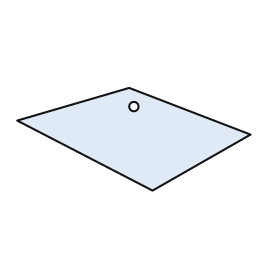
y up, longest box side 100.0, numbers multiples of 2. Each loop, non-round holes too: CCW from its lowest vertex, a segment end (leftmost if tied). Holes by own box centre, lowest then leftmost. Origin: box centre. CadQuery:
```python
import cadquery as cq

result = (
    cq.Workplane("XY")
    .moveTo(8.0, -22.0)
    .lineTo(50.0, 2.0)
    .lineTo(-2.0, 22.0)
    .lineTo(-50.0, 8.0)
    .close()
    .moveTo(0.0, 14.0)
    .circle(2.0)
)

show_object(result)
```